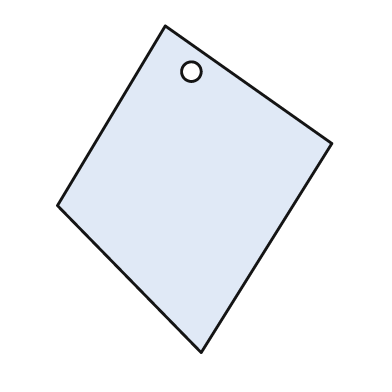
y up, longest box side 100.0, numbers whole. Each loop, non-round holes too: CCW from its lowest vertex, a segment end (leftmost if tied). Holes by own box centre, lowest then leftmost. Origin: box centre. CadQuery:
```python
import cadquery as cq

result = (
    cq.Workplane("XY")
    .moveTo(2.0, -50.0)
    .lineTo(42.0, 14.0)
    .lineTo(-9.0, 50.0)
    .lineTo(-42.0, -5.0)
    .close()
    .moveTo(-1.0, 36.0)
    .circle(3.0)
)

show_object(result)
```